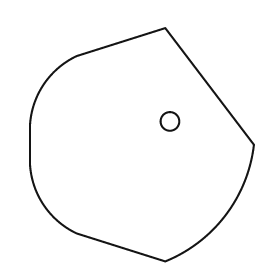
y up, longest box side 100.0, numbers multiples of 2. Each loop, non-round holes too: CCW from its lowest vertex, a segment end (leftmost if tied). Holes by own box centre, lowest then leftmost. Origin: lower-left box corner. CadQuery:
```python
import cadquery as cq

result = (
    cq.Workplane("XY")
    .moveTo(58.0, 0.0)
    .threePointArc((84.0, 20.0), (96.0, 50.0))
    .lineTo(58.0, 100.0)
    .lineTo(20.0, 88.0)
    .threePointArc((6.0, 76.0), (0.0, 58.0))
    .lineTo(0.0, 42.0)
    .threePointArc((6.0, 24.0), (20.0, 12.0))
    .close()
    .moveTo(60.0, 60.0)
    .circle(4.0)
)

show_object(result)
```